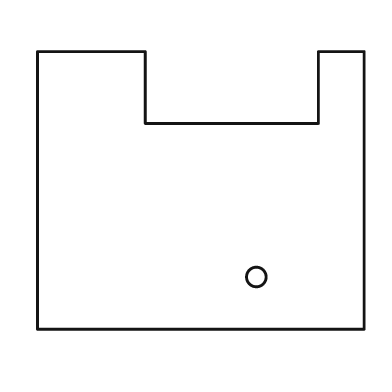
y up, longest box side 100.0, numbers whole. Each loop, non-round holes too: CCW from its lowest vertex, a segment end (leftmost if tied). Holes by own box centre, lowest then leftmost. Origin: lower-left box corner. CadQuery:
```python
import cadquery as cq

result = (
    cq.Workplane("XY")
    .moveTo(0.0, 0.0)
    .lineTo(100.0, 0.0)
    .lineTo(100.0, 85.0)
    .lineTo(86.0, 85.0)
    .lineTo(86.0, 63.0)
    .lineTo(33.0, 63.0)
    .lineTo(33.0, 85.0)
    .lineTo(0.0, 85.0)
    .close()
    .moveTo(67.0, 16.0)
    .circle(3.0)
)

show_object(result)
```